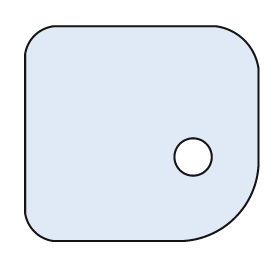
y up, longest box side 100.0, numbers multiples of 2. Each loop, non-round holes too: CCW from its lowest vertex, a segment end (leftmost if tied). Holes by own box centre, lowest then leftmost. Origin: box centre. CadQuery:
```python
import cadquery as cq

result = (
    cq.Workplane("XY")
    .moveTo(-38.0, -46.0)
    .lineTo(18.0, -46.0)
    .threePointArc((40.0, -36.0), (50.0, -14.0))
    .lineTo(50.0, 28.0)
    .threePointArc((44.0, 40.0), (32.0, 46.0))
    .lineTo(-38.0, 46.0)
    .threePointArc((-46.0, 42.0), (-50.0, 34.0))
    .lineTo(-50.0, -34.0)
    .threePointArc((-46.0, -42.0), (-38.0, -46.0))
    .close()
    .moveTo(22.0, -10.0)
    .circle(8.0)
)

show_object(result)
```